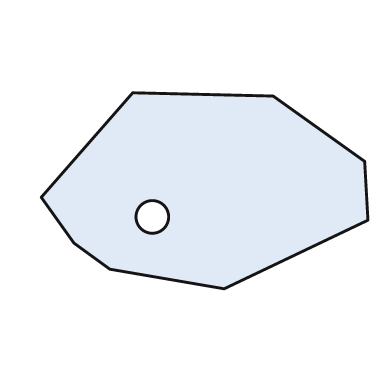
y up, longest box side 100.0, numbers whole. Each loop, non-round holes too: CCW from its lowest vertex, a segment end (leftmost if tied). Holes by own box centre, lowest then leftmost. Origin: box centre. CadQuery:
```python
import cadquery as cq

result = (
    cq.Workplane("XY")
    .moveTo(6.0, -30.0)
    .lineTo(50.0, -9.0)
    .lineTo(49.0, 9.0)
    .lineTo(21.0, 29.0)
    .lineTo(-22.0, 30.0)
    .lineTo(-50.0, -2.0)
    .lineTo(-40.0, -16.0)
    .lineTo(-29.0, -24.0)
    .close()
    .moveTo(-16.0, -8.0)
    .circle(5.0)
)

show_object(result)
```